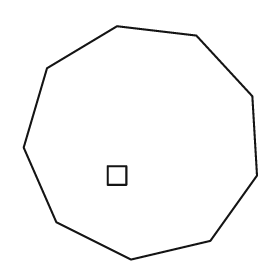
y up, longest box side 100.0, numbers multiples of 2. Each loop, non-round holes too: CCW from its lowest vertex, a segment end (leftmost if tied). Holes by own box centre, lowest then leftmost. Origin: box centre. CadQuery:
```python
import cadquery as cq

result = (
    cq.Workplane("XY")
    .moveTo(-4.0, -50.0)
    .lineTo(30.0, -42.0)
    .lineTo(50.0, -14.0)
    .lineTo(48.0, 20.0)
    .lineTo(24.0, 46.0)
    .lineTo(-10.0, 50.0)
    .lineTo(-40.0, 32.0)
    .lineTo(-50.0, -2.0)
    .lineTo(-36.0, -34.0)
    .close()
    .moveTo(-14.0, -18.0)
    .lineTo(-6.0, -18.0)
    .lineTo(-6.0, -10.0)
    .lineTo(-14.0, -10.0)
    .close()
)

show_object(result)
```